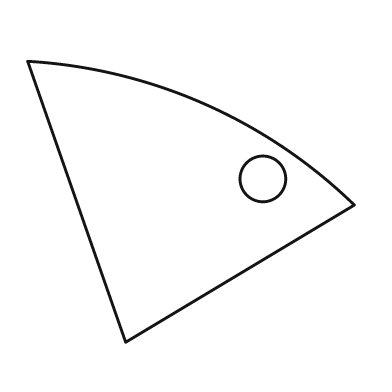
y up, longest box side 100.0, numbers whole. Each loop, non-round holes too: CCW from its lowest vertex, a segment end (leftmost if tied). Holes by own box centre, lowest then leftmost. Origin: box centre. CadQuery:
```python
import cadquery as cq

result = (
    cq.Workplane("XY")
    .moveTo(-20.0, -43.0)
    .lineTo(50.0, -1.0)
    .threePointArc((4.0, 30.0), (-50.0, 43.0))
    .close()
    .moveTo(22.0, 7.0)
    .circle(7.0)
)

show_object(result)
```